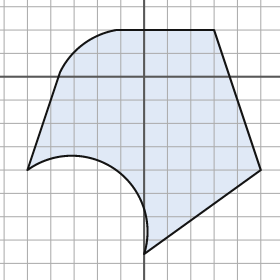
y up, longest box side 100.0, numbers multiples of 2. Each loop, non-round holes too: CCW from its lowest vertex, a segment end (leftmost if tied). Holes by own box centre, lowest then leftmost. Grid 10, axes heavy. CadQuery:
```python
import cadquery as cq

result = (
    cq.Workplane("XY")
    .moveTo(0.0, -76.0)
    .lineTo(50.0, -40.0)
    .lineTo(30.0, 20.0)
    .lineTo(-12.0, 20.0)
    .threePointArc((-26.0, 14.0), (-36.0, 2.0))
    .lineTo(-50.0, -40.0)
    .threePointArc((-12.0, -40.0), (0.0, -76.0))
    .close()
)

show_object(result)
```